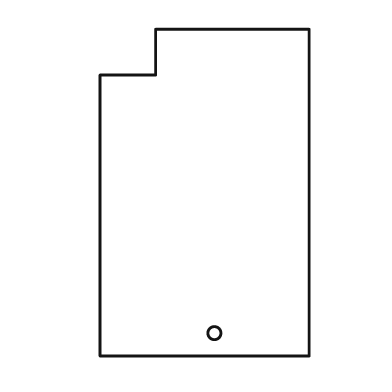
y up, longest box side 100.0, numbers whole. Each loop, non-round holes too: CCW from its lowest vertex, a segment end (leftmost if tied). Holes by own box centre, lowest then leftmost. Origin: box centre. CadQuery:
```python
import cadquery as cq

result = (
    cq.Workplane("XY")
    .moveTo(-32.0, -50.0)
    .lineTo(32.0, -50.0)
    .lineTo(32.0, 50.0)
    .lineTo(-15.0, 50.0)
    .lineTo(-15.0, 36.0)
    .lineTo(-32.0, 36.0)
    .close()
    .moveTo(3.0, -43.0)
    .circle(2.0)
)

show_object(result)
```